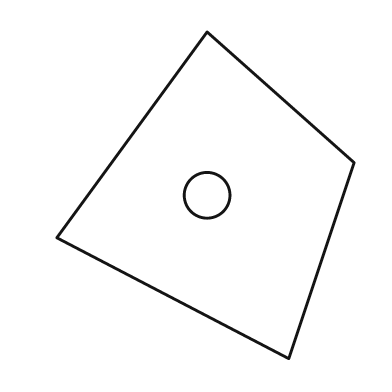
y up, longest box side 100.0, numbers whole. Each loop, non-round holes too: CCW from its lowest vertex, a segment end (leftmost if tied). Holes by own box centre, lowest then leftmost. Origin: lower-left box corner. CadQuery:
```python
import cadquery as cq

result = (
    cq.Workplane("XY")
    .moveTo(71.0, 0.0)
    .lineTo(91.0, 60.0)
    .lineTo(46.0, 100.0)
    .lineTo(0.0, 37.0)
    .close()
    .moveTo(46.0, 50.0)
    .circle(7.0)
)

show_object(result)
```